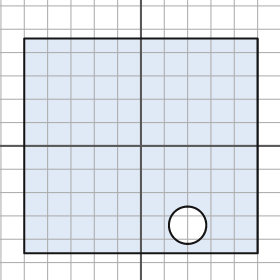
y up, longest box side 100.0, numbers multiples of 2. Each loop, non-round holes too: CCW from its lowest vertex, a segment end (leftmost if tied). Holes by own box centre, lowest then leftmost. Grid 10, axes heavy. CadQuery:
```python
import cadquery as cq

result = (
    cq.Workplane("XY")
    .moveTo(-50.0, -46.0)
    .lineTo(50.0, -46.0)
    .lineTo(50.0, 46.0)
    .lineTo(-50.0, 46.0)
    .close()
    .moveTo(20.0, -34.0)
    .circle(8.0)
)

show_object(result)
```